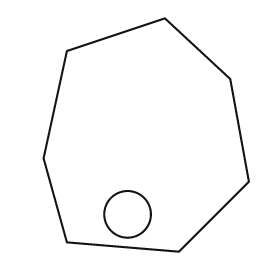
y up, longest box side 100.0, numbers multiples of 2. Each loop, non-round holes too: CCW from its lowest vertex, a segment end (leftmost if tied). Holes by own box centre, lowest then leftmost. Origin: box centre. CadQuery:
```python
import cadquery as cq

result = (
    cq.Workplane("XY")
    .moveTo(14.0, -50.0)
    .lineTo(44.0, -20.0)
    .lineTo(36.0, 24.0)
    .lineTo(8.0, 50.0)
    .lineTo(-34.0, 36.0)
    .lineTo(-44.0, -10.0)
    .lineTo(-34.0, -46.0)
    .close()
    .moveTo(-8.0, -34.0)
    .circle(10.0)
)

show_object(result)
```